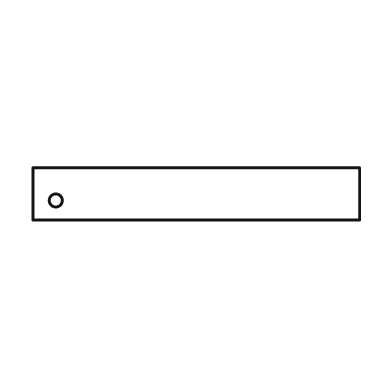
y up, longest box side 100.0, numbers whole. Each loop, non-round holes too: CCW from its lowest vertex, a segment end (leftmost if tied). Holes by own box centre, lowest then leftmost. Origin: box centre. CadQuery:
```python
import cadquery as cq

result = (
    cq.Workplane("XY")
    .moveTo(-50.0, -8.0)
    .lineTo(50.0, -8.0)
    .lineTo(50.0, 8.0)
    .lineTo(-50.0, 8.0)
    .close()
    .moveTo(-43.0, -2.0)
    .circle(2.0)
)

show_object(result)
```